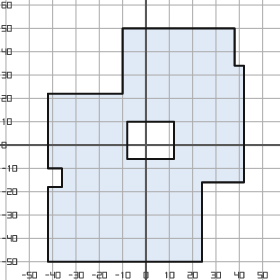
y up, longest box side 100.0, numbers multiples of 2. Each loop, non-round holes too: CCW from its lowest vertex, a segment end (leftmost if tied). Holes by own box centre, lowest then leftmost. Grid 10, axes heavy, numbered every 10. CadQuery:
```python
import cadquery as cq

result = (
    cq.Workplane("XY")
    .moveTo(-42.0, -50.0)
    .lineTo(24.0, -50.0)
    .lineTo(24.0, -16.0)
    .lineTo(42.0, -16.0)
    .lineTo(42.0, 34.0)
    .lineTo(38.0, 34.0)
    .lineTo(38.0, 50.0)
    .lineTo(-10.0, 50.0)
    .lineTo(-10.0, 22.0)
    .lineTo(-42.0, 22.0)
    .lineTo(-42.0, -10.0)
    .lineTo(-36.0, -10.0)
    .lineTo(-36.0, -18.0)
    .lineTo(-42.0, -18.0)
    .close()
    .moveTo(-8.0, -6.0)
    .lineTo(12.0, -6.0)
    .lineTo(12.0, 10.0)
    .lineTo(-8.0, 10.0)
    .close()
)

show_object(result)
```